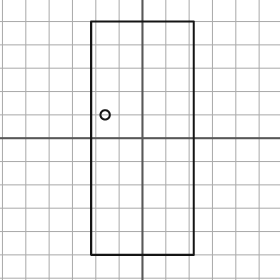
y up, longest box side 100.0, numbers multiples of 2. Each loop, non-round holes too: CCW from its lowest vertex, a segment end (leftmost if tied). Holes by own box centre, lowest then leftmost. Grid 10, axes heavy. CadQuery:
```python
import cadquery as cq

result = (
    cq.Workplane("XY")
    .moveTo(-22.0, -50.0)
    .lineTo(22.0, -50.0)
    .lineTo(22.0, 50.0)
    .lineTo(-22.0, 50.0)
    .close()
    .moveTo(-16.0, 10.0)
    .circle(2.0)
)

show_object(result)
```